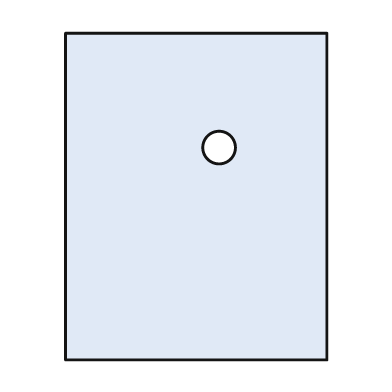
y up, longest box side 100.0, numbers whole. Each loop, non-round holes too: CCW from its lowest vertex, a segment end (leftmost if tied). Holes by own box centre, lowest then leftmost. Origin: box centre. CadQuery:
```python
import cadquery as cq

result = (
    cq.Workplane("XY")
    .moveTo(-40.0, -50.0)
    .lineTo(40.0, -50.0)
    .lineTo(40.0, 50.0)
    .lineTo(-40.0, 50.0)
    .close()
    .moveTo(7.0, 15.0)
    .circle(5.0)
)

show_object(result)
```